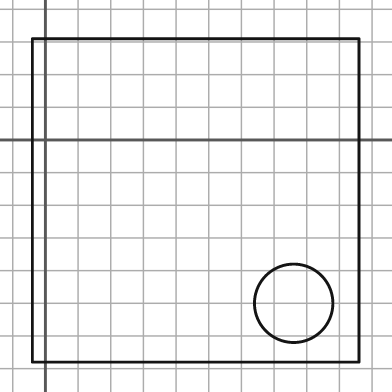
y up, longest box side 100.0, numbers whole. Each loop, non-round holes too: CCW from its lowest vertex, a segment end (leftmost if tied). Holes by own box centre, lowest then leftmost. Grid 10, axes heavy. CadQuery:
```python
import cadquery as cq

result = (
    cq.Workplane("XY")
    .moveTo(-4.0, -68.0)
    .lineTo(96.0, -68.0)
    .lineTo(96.0, 31.0)
    .lineTo(-4.0, 31.0)
    .close()
    .moveTo(76.0, -50.0)
    .circle(12.0)
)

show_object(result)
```